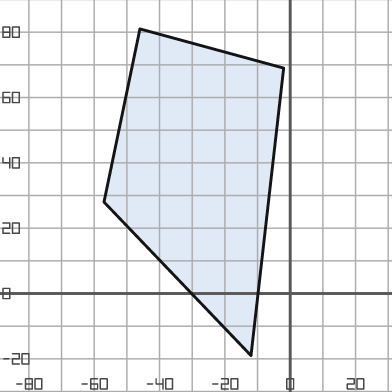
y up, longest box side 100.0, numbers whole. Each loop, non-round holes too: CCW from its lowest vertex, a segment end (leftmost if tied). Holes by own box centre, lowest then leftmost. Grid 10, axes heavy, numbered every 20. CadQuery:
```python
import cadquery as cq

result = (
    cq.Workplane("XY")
    .moveTo(-12.0, -19.0)
    .lineTo(-2.0, 69.0)
    .lineTo(-46.0, 81.0)
    .lineTo(-57.0, 28.0)
    .close()
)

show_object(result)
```